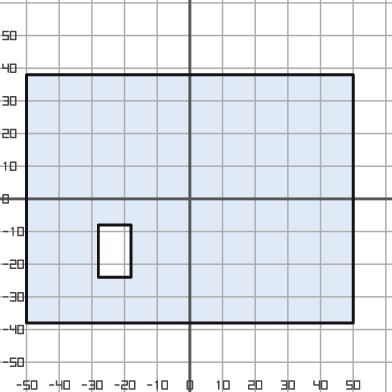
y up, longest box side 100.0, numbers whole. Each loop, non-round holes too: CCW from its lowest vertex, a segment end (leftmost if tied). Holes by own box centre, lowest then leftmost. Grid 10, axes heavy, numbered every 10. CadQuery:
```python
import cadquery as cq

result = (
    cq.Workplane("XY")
    .moveTo(-50.0, -38.0)
    .lineTo(50.0, -38.0)
    .lineTo(50.0, 38.0)
    .lineTo(-50.0, 38.0)
    .close()
    .moveTo(-28.0, -24.0)
    .lineTo(-18.0, -24.0)
    .lineTo(-18.0, -8.0)
    .lineTo(-28.0, -8.0)
    .close()
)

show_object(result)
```